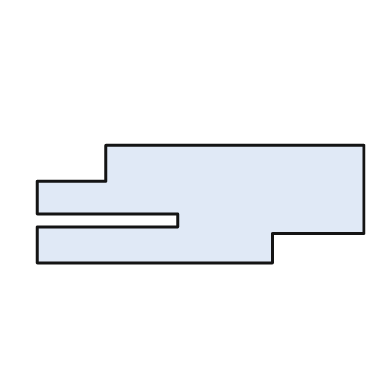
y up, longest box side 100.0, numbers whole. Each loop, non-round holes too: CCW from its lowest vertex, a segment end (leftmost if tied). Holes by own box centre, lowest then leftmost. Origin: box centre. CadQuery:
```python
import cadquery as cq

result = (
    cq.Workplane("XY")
    .moveTo(-50.0, -18.0)
    .lineTo(22.0, -18.0)
    .lineTo(22.0, -9.0)
    .lineTo(50.0, -9.0)
    .lineTo(50.0, 18.0)
    .lineTo(-29.0, 18.0)
    .lineTo(-29.0, 7.0)
    .lineTo(-50.0, 7.0)
    .lineTo(-50.0, -3.0)
    .lineTo(-7.0, -3.0)
    .lineTo(-7.0, -7.0)
    .lineTo(-50.0, -7.0)
    .close()
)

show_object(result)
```